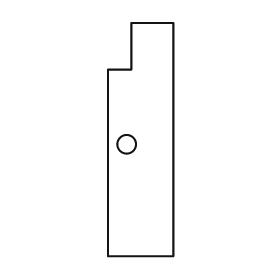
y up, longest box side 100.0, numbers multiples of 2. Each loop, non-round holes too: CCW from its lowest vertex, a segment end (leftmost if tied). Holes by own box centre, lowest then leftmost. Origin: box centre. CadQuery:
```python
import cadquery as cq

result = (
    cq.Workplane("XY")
    .moveTo(-14.0, -50.0)
    .lineTo(14.0, -50.0)
    .lineTo(14.0, 50.0)
    .lineTo(-4.0, 50.0)
    .lineTo(-4.0, 30.0)
    .lineTo(-14.0, 30.0)
    .close()
    .moveTo(-6.0, -2.0)
    .circle(4.0)
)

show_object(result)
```